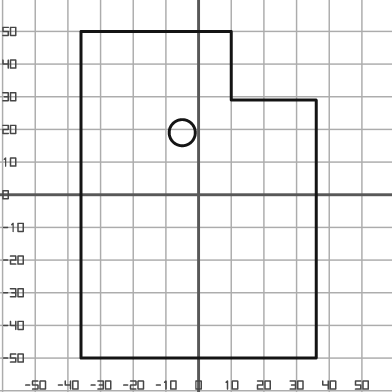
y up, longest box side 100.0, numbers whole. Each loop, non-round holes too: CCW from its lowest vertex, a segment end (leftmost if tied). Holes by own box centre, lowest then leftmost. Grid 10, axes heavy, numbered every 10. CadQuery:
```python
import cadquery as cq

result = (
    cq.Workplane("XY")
    .moveTo(-36.0, -50.0)
    .lineTo(36.0, -50.0)
    .lineTo(36.0, 29.0)
    .lineTo(10.0, 29.0)
    .lineTo(10.0, 50.0)
    .lineTo(-36.0, 50.0)
    .close()
    .moveTo(-5.0, 19.0)
    .circle(4.0)
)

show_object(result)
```